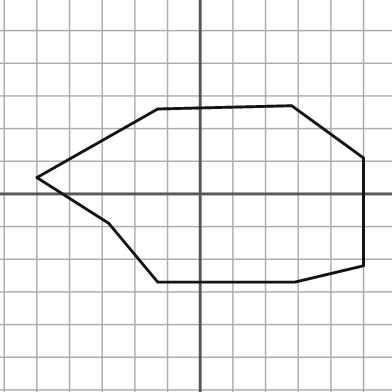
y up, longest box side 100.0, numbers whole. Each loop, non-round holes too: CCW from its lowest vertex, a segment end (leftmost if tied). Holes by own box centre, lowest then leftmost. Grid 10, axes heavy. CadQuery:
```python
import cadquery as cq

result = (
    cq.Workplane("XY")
    .moveTo(-13.0, -27.0)
    .lineTo(29.0, -27.0)
    .lineTo(50.0, -22.0)
    .lineTo(50.0, 11.0)
    .lineTo(28.0, 27.0)
    .lineTo(-13.0, 26.0)
    .lineTo(-50.0, 5.0)
    .lineTo(-28.0, -9.0)
    .close()
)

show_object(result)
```